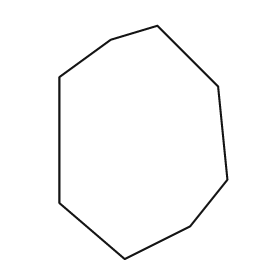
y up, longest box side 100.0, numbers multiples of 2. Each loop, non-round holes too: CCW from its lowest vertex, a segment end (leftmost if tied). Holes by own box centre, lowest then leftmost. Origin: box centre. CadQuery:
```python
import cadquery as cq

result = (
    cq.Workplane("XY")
    .moveTo(-8.0, -50.0)
    .lineTo(20.0, -36.0)
    .lineTo(36.0, -16.0)
    .lineTo(32.0, 24.0)
    .lineTo(6.0, 50.0)
    .lineTo(-14.0, 44.0)
    .lineTo(-36.0, 28.0)
    .lineTo(-36.0, -26.0)
    .close()
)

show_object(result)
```